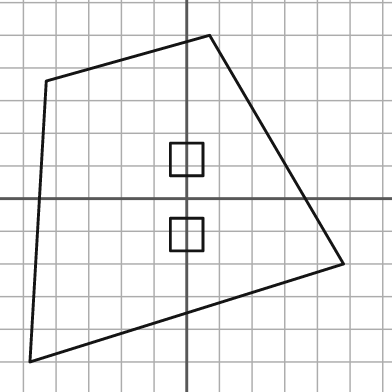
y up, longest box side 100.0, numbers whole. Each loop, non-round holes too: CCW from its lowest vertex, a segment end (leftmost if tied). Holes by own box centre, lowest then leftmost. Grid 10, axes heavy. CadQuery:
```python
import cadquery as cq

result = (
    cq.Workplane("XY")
    .moveTo(-48.0, -50.0)
    .lineTo(48.0, -20.0)
    .lineTo(7.0, 50.0)
    .lineTo(-43.0, 36.0)
    .close()
    .moveTo(-5.0, -16.0)
    .lineTo(5.0, -16.0)
    .lineTo(5.0, -6.0)
    .lineTo(-5.0, -6.0)
    .close()
    .moveTo(-5.0, 7.0)
    .lineTo(5.0, 7.0)
    .lineTo(5.0, 17.0)
    .lineTo(-5.0, 17.0)
    .close()
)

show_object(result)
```